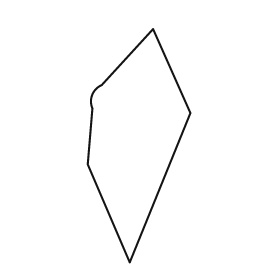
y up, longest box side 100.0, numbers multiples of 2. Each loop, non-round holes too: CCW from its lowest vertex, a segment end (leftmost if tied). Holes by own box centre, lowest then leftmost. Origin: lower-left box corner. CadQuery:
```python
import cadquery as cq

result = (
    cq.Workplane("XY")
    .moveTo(18.0, 0.0)
    .lineTo(44.0, 64.0)
    .lineTo(28.0, 100.0)
    .lineTo(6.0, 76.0)
    .threePointArc((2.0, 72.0), (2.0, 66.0))
    .lineTo(0.0, 42.0)
    .close()
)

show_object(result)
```